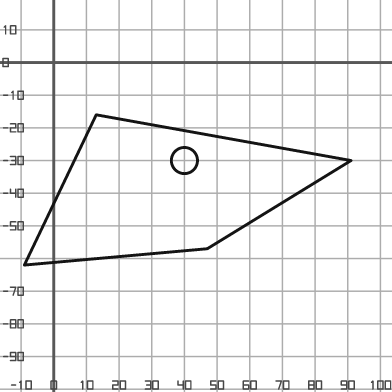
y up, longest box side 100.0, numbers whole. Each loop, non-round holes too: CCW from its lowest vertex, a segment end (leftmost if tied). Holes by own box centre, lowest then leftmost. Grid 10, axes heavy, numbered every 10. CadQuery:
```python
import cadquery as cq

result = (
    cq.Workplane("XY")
    .moveTo(-9.0, -62.0)
    .lineTo(47.0, -57.0)
    .lineTo(91.0, -30.0)
    .lineTo(13.0, -16.0)
    .close()
    .moveTo(40.0, -30.0)
    .circle(4.0)
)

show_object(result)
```